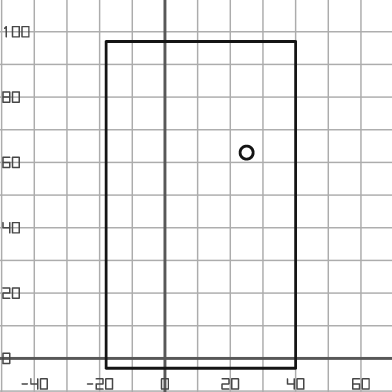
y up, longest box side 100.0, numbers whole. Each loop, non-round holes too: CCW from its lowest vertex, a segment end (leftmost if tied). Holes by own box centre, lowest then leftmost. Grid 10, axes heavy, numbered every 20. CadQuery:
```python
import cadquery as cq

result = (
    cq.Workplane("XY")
    .moveTo(-18.0, -3.0)
    .lineTo(40.0, -3.0)
    .lineTo(40.0, 97.0)
    .lineTo(-18.0, 97.0)
    .close()
    .moveTo(25.0, 63.0)
    .circle(2.0)
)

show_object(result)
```